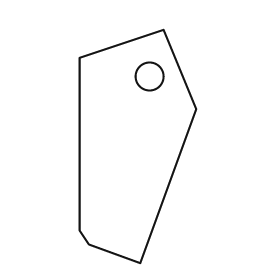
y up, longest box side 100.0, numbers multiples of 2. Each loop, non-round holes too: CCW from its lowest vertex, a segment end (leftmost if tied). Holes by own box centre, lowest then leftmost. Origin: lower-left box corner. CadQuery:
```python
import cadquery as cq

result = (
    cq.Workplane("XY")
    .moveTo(26.0, 0.0)
    .lineTo(50.0, 66.0)
    .lineTo(36.0, 100.0)
    .lineTo(0.0, 88.0)
    .lineTo(0.0, 14.0)
    .lineTo(4.0, 8.0)
    .close()
    .moveTo(30.0, 80.0)
    .circle(6.0)
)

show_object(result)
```